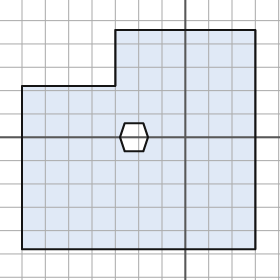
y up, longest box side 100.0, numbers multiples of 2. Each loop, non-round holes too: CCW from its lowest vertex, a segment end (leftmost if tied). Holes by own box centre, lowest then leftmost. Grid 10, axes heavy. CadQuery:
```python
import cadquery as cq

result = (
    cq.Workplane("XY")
    .moveTo(-70.0, -48.0)
    .lineTo(30.0, -48.0)
    .lineTo(30.0, 46.0)
    .lineTo(-30.0, 46.0)
    .lineTo(-30.0, 22.0)
    .lineTo(-70.0, 22.0)
    .close()
    .moveTo(-26.0, -6.0)
    .lineTo(-18.0, -6.0)
    .lineTo(-16.0, 0.0)
    .lineTo(-18.0, 6.0)
    .lineTo(-26.0, 6.0)
    .lineTo(-28.0, 0.0)
    .close()
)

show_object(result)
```